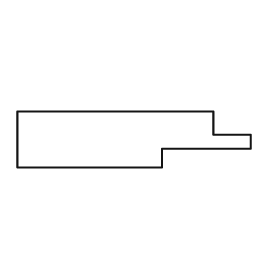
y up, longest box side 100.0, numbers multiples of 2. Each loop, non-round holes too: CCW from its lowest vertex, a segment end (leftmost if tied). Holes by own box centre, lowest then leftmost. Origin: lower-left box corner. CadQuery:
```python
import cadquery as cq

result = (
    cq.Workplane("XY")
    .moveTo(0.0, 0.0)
    .lineTo(62.0, 0.0)
    .lineTo(62.0, 8.0)
    .lineTo(100.0, 8.0)
    .lineTo(100.0, 14.0)
    .lineTo(84.0, 14.0)
    .lineTo(84.0, 24.0)
    .lineTo(0.0, 24.0)
    .close()
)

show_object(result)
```